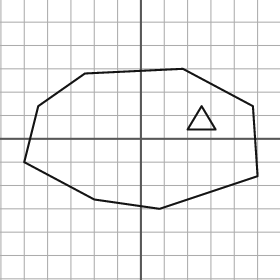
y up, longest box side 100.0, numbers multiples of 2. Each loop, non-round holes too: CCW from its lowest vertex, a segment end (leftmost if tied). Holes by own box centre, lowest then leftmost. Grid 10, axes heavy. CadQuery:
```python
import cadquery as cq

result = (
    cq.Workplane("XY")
    .moveTo(8.0, -30.0)
    .lineTo(50.0, -16.0)
    .lineTo(48.0, 14.0)
    .lineTo(18.0, 30.0)
    .lineTo(-24.0, 28.0)
    .lineTo(-44.0, 14.0)
    .lineTo(-50.0, -10.0)
    .lineTo(-20.0, -26.0)
    .close()
    .moveTo(20.0, 4.0)
    .lineTo(32.0, 4.0)
    .lineTo(26.0, 14.0)
    .close()
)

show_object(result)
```